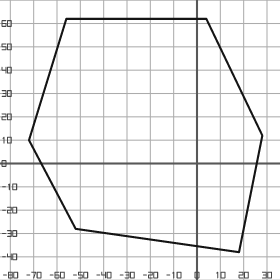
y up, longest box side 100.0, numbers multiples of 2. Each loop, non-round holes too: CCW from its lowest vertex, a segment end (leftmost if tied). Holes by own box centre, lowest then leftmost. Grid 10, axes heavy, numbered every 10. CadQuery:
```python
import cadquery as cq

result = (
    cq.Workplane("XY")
    .moveTo(18.0, -38.0)
    .lineTo(28.0, 12.0)
    .lineTo(4.0, 62.0)
    .lineTo(-56.0, 62.0)
    .lineTo(-72.0, 10.0)
    .lineTo(-52.0, -28.0)
    .close()
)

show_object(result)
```